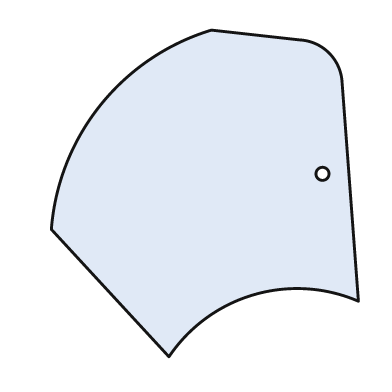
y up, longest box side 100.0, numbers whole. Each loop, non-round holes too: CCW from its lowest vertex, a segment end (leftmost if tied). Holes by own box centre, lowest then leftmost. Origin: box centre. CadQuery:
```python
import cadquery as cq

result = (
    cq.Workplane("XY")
    .moveTo(-11.0, -50.0)
    .threePointArc((15.0, -31.0), (47.0, -33.0))
    .lineTo(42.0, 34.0)
    .threePointArc((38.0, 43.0), (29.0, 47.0))
    .lineTo(2.0, 50.0)
    .threePointArc((-32.0, 27.0), (-47.0, -11.0))
    .close()
    .moveTo(36.0, 6.0)
    .circle(2.0)
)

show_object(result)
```